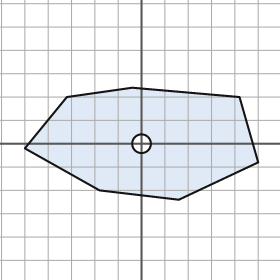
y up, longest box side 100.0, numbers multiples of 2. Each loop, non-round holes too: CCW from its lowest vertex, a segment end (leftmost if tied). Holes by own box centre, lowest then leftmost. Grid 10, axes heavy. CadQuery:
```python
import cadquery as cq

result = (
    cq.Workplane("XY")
    .moveTo(16.0, -24.0)
    .lineTo(50.0, -8.0)
    .lineTo(42.0, 20.0)
    .lineTo(-4.0, 24.0)
    .lineTo(-32.0, 20.0)
    .lineTo(-50.0, -2.0)
    .lineTo(-18.0, -20.0)
    .close()
    .moveTo(0.0, 0.0)
    .circle(4.0)
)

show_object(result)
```